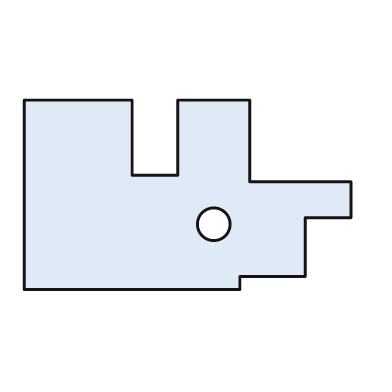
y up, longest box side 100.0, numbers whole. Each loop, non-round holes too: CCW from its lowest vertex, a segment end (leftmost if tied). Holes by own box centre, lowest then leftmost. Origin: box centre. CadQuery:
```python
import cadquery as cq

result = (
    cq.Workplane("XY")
    .moveTo(-50.0, -29.0)
    .lineTo(16.0, -29.0)
    .lineTo(16.0, -25.0)
    .lineTo(36.0, -25.0)
    .lineTo(36.0, -7.0)
    .lineTo(50.0, -7.0)
    .lineTo(50.0, 4.0)
    .lineTo(19.0, 4.0)
    .lineTo(19.0, 29.0)
    .lineTo(-3.0, 29.0)
    .lineTo(-3.0, 6.0)
    .lineTo(-17.0, 6.0)
    .lineTo(-17.0, 29.0)
    .lineTo(-50.0, 29.0)
    .close()
    .moveTo(8.0, -9.0)
    .circle(5.0)
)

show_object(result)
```